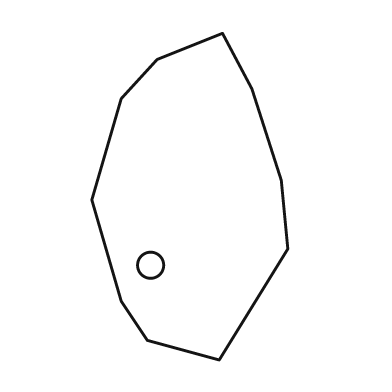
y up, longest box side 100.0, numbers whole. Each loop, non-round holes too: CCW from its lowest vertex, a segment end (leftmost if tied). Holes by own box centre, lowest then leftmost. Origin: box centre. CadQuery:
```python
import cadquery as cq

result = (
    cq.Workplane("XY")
    .moveTo(9.0, -50.0)
    .lineTo(30.0, -16.0)
    .lineTo(28.0, 5.0)
    .lineTo(19.0, 33.0)
    .lineTo(10.0, 50.0)
    .lineTo(-10.0, 42.0)
    .lineTo(-21.0, 30.0)
    .lineTo(-30.0, -1.0)
    .lineTo(-21.0, -32.0)
    .lineTo(-13.0, -44.0)
    .close()
    .moveTo(-12.0, -21.0)
    .circle(4.0)
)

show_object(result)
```